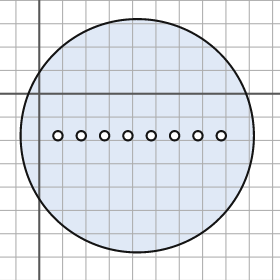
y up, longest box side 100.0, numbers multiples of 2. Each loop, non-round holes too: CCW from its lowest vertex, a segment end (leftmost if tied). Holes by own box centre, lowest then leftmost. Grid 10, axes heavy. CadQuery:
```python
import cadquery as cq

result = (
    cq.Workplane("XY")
    .moveTo(42.0, -18.0)
    .circle(50.0)
    .moveTo(8.0, -18.0)
    .circle(2.0)
    .moveTo(18.0, -18.0)
    .circle(2.0)
    .moveTo(28.0, -18.0)
    .circle(2.0)
    .moveTo(38.0, -18.0)
    .circle(2.0)
    .moveTo(48.0, -18.0)
    .circle(2.0)
    .moveTo(58.0, -18.0)
    .circle(2.0)
    .moveTo(68.0, -18.0)
    .circle(2.0)
    .moveTo(78.0, -18.0)
    .circle(2.0)
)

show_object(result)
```